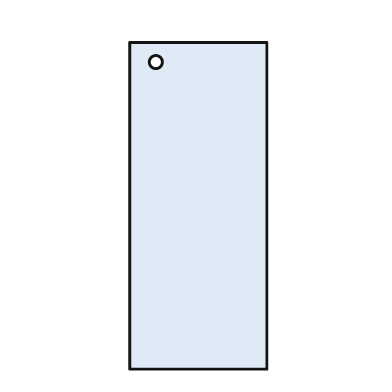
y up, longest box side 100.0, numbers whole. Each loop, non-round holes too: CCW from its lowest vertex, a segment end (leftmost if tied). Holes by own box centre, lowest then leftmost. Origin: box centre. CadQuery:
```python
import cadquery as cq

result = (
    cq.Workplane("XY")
    .moveTo(-21.0, -50.0)
    .lineTo(21.0, -50.0)
    .lineTo(21.0, 50.0)
    .lineTo(-21.0, 50.0)
    .close()
    .moveTo(-13.0, 44.0)
    .circle(2.0)
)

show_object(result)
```